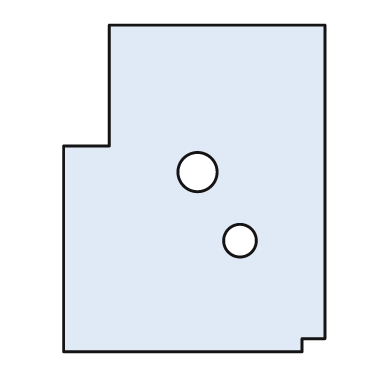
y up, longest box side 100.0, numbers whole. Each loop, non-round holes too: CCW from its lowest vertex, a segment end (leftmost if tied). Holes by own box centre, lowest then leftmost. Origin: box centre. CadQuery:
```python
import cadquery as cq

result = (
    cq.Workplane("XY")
    .moveTo(-40.0, -50.0)
    .lineTo(33.0, -50.0)
    .lineTo(33.0, -46.0)
    .lineTo(40.0, -46.0)
    .lineTo(40.0, 50.0)
    .lineTo(-26.0, 50.0)
    .lineTo(-26.0, 13.0)
    .lineTo(-40.0, 13.0)
    .close()
    .moveTo(14.0, -16.0)
    .circle(5.0)
    .moveTo(1.0, 5.0)
    .circle(6.0)
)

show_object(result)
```